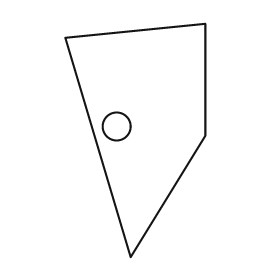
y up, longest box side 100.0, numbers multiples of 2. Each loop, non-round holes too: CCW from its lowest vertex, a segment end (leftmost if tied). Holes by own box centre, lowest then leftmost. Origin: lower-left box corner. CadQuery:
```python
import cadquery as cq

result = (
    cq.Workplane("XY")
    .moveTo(28.0, 0.0)
    .lineTo(60.0, 52.0)
    .lineTo(60.0, 100.0)
    .lineTo(0.0, 94.0)
    .close()
    .moveTo(22.0, 56.0)
    .circle(6.0)
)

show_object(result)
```